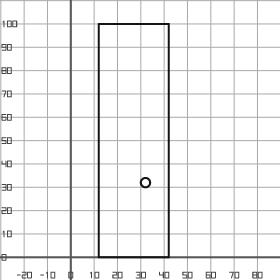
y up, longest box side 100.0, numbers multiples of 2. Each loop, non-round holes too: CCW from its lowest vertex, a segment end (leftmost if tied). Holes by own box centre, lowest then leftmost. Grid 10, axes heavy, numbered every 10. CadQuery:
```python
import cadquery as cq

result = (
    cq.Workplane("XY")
    .moveTo(12.0, 0.0)
    .lineTo(42.0, 0.0)
    .lineTo(42.0, 100.0)
    .lineTo(12.0, 100.0)
    .close()
    .moveTo(32.0, 32.0)
    .circle(2.0)
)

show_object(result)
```